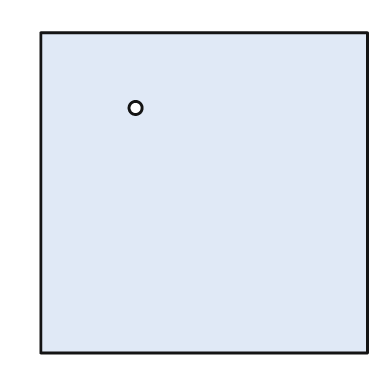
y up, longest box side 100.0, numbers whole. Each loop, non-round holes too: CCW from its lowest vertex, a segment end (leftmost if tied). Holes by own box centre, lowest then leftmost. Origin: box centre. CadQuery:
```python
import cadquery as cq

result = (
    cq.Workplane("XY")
    .moveTo(-50.0, -49.0)
    .lineTo(50.0, -49.0)
    .lineTo(50.0, 49.0)
    .lineTo(-50.0, 49.0)
    .close()
    .moveTo(-21.0, 26.0)
    .circle(2.0)
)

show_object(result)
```